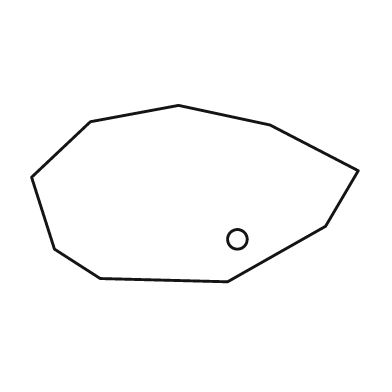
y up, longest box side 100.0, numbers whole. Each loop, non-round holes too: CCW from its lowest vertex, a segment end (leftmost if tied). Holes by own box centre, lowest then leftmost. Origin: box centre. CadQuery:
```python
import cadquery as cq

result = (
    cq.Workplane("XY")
    .moveTo(10.0, -27.0)
    .lineTo(40.0, -10.0)
    .lineTo(50.0, 7.0)
    .lineTo(23.0, 21.0)
    .lineTo(-5.0, 27.0)
    .lineTo(-32.0, 22.0)
    .lineTo(-50.0, 5.0)
    .lineTo(-43.0, -17.0)
    .lineTo(-29.0, -26.0)
    .close()
    .moveTo(13.0, -14.0)
    .circle(3.0)
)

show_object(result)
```